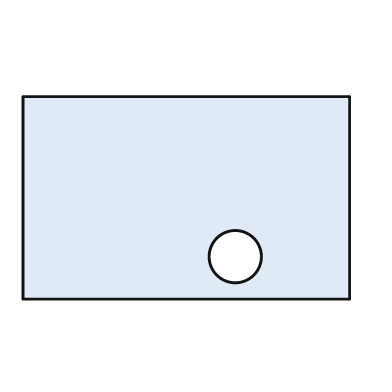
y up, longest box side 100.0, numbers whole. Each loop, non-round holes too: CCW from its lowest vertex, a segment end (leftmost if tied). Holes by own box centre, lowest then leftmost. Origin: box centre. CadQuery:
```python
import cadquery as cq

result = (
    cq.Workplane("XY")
    .moveTo(-50.0, -31.0)
    .lineTo(50.0, -31.0)
    .lineTo(50.0, 31.0)
    .lineTo(-50.0, 31.0)
    .close()
    .moveTo(15.0, -18.0)
    .circle(8.0)
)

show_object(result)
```